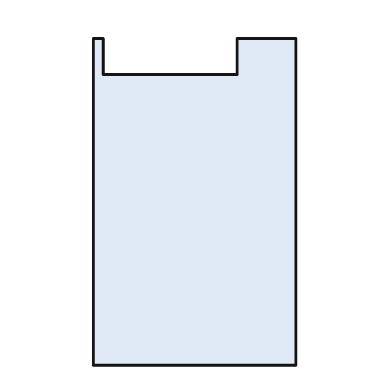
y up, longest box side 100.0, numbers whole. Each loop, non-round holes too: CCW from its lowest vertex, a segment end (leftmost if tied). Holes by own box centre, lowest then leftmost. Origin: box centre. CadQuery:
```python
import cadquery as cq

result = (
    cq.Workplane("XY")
    .moveTo(-31.0, -50.0)
    .lineTo(31.0, -50.0)
    .lineTo(31.0, 50.0)
    .lineTo(13.0, 50.0)
    .lineTo(13.0, 39.0)
    .lineTo(-28.0, 39.0)
    .lineTo(-28.0, 50.0)
    .lineTo(-31.0, 50.0)
    .close()
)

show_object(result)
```